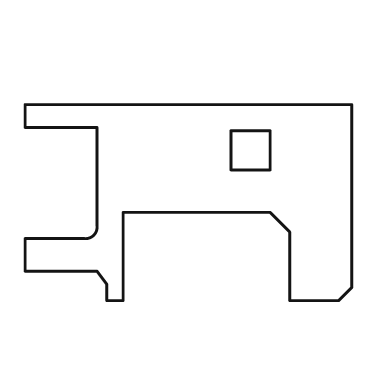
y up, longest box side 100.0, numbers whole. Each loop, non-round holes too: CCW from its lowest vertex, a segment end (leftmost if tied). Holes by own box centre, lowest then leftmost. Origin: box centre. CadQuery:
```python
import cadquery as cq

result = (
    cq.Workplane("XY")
    .moveTo(-25.0, -30.0)
    .lineTo(-20.0, -30.0)
    .lineTo(-20.0, -3.0)
    .lineTo(25.0, -3.0)
    .lineTo(31.0, -9.0)
    .lineTo(31.0, -30.0)
    .lineTo(46.0, -30.0)
    .lineTo(50.0, -26.0)
    .lineTo(50.0, 30.0)
    .lineTo(-50.0, 30.0)
    .lineTo(-50.0, 23.0)
    .lineTo(-28.0, 23.0)
    .lineTo(-28.0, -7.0)
    .threePointArc((-29.0, -10.0), (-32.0, -11.0))
    .lineTo(-50.0, -11.0)
    .lineTo(-50.0, -21.0)
    .lineTo(-28.0, -21.0)
    .lineTo(-25.0, -25.0)
    .close()
    .moveTo(13.0, 10.0)
    .lineTo(25.0, 10.0)
    .lineTo(25.0, 22.0)
    .lineTo(13.0, 22.0)
    .close()
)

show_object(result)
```